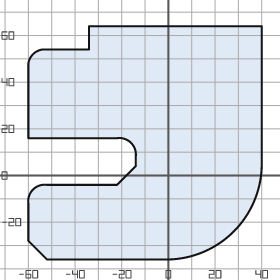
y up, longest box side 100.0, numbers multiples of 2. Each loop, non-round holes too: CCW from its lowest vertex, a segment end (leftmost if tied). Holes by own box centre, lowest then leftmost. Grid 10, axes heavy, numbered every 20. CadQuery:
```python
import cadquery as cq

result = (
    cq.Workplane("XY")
    .moveTo(-52.0, -36.0)
    .lineTo(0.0, -36.0)
    .threePointArc((28.0, -24.0), (40.0, 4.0))
    .lineTo(40.0, 64.0)
    .lineTo(-34.0, 64.0)
    .lineTo(-34.0, 54.0)
    .lineTo(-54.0, 54.0)
    .threePointArc((-58.0, 52.0), (-60.0, 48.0))
    .lineTo(-60.0, 16.0)
    .lineTo(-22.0, 16.0)
    .threePointArc((-16.0, 14.0), (-14.0, 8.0))
    .lineTo(-14.0, 4.0)
    .lineTo(-22.0, -4.0)
    .lineTo(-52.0, -4.0)
    .threePointArc((-58.0, -6.0), (-60.0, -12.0))
    .lineTo(-60.0, -28.0)
    .close()
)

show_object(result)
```